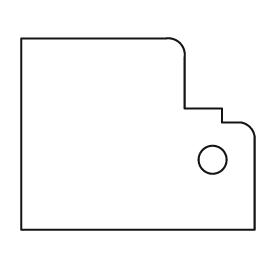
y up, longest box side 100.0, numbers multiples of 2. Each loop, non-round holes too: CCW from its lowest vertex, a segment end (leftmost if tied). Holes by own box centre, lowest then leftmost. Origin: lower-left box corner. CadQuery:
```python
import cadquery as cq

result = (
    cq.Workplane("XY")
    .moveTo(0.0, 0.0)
    .lineTo(100.0, 0.0)
    .lineTo(100.0, 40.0)
    .threePointArc((98.0, 44.0), (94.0, 46.0))
    .lineTo(86.0, 46.0)
    .lineTo(86.0, 52.0)
    .lineTo(70.0, 52.0)
    .lineTo(70.0, 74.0)
    .threePointArc((68.0, 80.0), (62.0, 82.0))
    .lineTo(0.0, 82.0)
    .close()
    .moveTo(82.0, 30.0)
    .circle(6.0)
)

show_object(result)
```